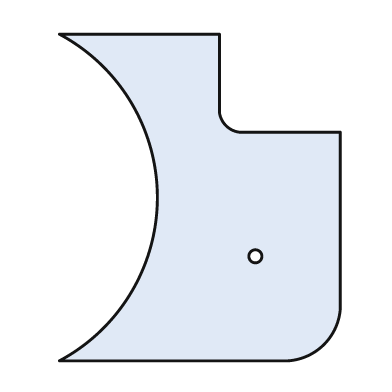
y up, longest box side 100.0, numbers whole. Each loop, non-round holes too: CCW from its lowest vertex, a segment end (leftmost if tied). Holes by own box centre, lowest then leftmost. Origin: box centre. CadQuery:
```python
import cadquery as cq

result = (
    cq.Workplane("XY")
    .moveTo(-43.0, -50.0)
    .lineTo(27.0, -50.0)
    .threePointArc((38.0, -45.0), (43.0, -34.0))
    .lineTo(43.0, 20.0)
    .lineTo(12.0, 20.0)
    .threePointArc((8.0, 22.0), (6.0, 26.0))
    .lineTo(6.0, 50.0)
    .lineTo(-43.0, 50.0)
    .threePointArc((-13.0, 0.0), (-43.0, -50.0))
    .close()
    .moveTo(17.0, -18.0)
    .circle(2.0)
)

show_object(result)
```